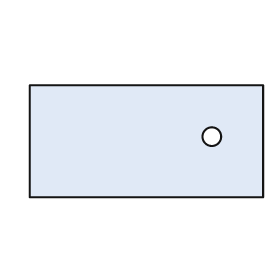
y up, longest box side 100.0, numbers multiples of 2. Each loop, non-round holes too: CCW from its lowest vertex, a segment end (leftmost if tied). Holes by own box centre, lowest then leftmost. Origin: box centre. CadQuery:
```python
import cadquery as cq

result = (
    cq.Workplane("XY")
    .moveTo(-50.0, -24.0)
    .lineTo(50.0, -24.0)
    .lineTo(50.0, 24.0)
    .lineTo(-50.0, 24.0)
    .close()
    .moveTo(28.0, 2.0)
    .circle(4.0)
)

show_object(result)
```